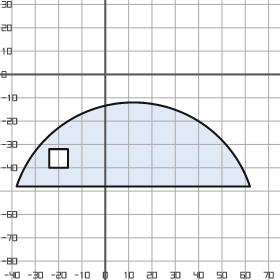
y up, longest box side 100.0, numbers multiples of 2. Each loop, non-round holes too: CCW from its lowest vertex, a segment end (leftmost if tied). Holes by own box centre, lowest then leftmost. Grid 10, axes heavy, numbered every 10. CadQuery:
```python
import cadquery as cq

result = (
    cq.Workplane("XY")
    .moveTo(-38.0, -48.0)
    .lineTo(62.0, -48.0)
    .threePointArc((12.0, -12.0), (-38.0, -48.0))
    .close()
    .moveTo(-24.0, -40.0)
    .lineTo(-16.0, -40.0)
    .lineTo(-16.0, -32.0)
    .lineTo(-24.0, -32.0)
    .close()
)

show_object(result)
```